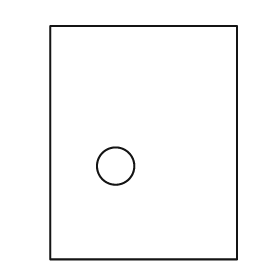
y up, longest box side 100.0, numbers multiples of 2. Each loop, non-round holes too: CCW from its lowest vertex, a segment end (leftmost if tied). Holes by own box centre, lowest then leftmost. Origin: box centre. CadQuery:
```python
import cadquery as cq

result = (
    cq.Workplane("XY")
    .moveTo(-40.0, -50.0)
    .lineTo(40.0, -50.0)
    .lineTo(40.0, 50.0)
    .lineTo(-40.0, 50.0)
    .close()
    .moveTo(-12.0, -10.0)
    .circle(8.0)
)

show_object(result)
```